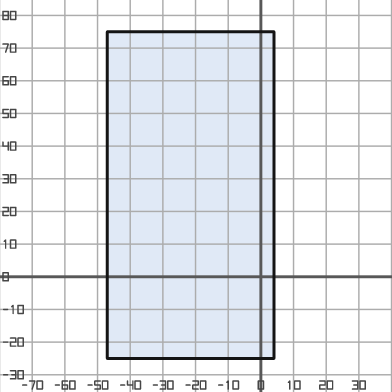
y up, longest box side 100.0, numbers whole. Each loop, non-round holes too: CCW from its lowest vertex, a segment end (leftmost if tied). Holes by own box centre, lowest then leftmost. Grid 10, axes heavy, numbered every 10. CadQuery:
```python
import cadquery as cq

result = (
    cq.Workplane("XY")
    .moveTo(-47.0, -25.0)
    .lineTo(4.0, -25.0)
    .lineTo(4.0, 75.0)
    .lineTo(-47.0, 75.0)
    .close()
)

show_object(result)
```